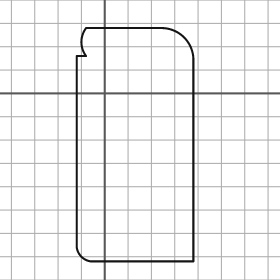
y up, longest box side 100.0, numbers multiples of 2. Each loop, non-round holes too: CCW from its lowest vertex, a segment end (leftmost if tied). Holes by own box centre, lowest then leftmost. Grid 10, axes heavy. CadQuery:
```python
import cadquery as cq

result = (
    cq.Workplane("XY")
    .moveTo(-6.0, -72.0)
    .lineTo(38.0, -72.0)
    .lineTo(38.0, 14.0)
    .threePointArc((34.0, 24.0), (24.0, 28.0))
    .lineTo(-8.0, 28.0)
    .threePointArc((-10.0, 22.0), (-8.0, 16.0))
    .lineTo(-12.0, 16.0)
    .lineTo(-12.0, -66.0)
    .threePointArc((-10.0, -70.0), (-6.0, -72.0))
    .close()
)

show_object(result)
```